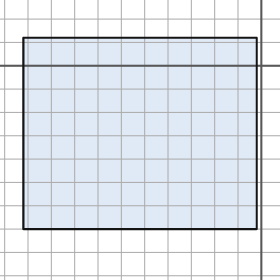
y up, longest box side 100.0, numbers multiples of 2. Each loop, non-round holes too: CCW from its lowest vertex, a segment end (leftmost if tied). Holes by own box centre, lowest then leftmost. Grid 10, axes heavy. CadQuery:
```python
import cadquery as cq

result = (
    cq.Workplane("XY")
    .moveTo(-102.0, -70.0)
    .lineTo(-2.0, -70.0)
    .lineTo(-2.0, 12.0)
    .lineTo(-102.0, 12.0)
    .close()
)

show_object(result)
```